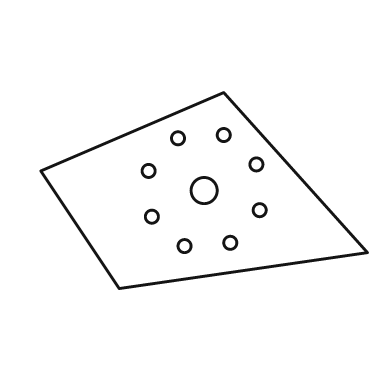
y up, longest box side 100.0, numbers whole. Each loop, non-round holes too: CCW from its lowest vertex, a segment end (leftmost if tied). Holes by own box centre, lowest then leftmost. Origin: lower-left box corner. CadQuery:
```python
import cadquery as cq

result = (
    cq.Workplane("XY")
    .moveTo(24.0, 0.0)
    .lineTo(100.0, 11.0)
    .lineTo(56.0, 60.0)
    .lineTo(0.0, 36.0)
    .close()
    .moveTo(44.0, 13.0)
    .circle(2.0)
    .moveTo(58.0, 14.0)
    .circle(2.0)
    .moveTo(34.0, 22.0)
    .circle(2.0)
    .moveTo(67.0, 24.0)
    .circle(2.0)
    .moveTo(50.0, 30.0)
    .circle(4.0)
    .moveTo(33.0, 36.0)
    .circle(2.0)
    .moveTo(66.0, 38.0)
    .circle(2.0)
    .moveTo(42.0, 46.0)
    .circle(2.0)
    .moveTo(56.0, 47.0)
    .circle(2.0)
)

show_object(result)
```